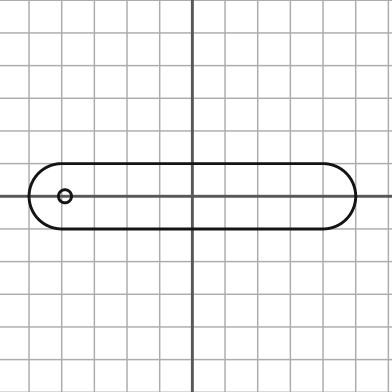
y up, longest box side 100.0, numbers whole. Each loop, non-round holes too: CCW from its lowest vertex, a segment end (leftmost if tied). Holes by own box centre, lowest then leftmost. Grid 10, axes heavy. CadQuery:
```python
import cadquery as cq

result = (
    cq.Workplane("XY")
    .moveTo(-40.0, -10.0)
    .lineTo(40.0, -10.0)
    .threePointArc((50.0, 0.0), (40.0, 10.0))
    .lineTo(-40.0, 10.0)
    .threePointArc((-50.0, 0.0), (-40.0, -10.0))
    .close()
    .moveTo(-39.0, 0.0)
    .circle(2.0)
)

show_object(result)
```